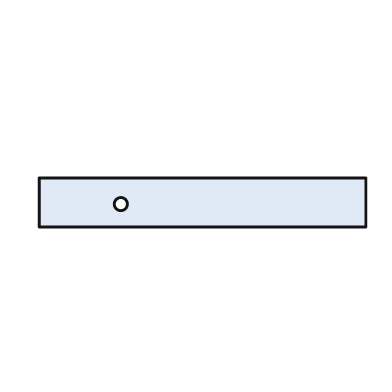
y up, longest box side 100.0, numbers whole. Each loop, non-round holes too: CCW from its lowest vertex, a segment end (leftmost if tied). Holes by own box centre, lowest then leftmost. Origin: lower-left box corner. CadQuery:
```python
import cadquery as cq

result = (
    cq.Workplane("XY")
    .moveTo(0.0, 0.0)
    .lineTo(100.0, 0.0)
    .lineTo(100.0, 15.0)
    .lineTo(0.0, 15.0)
    .close()
    .moveTo(25.0, 7.0)
    .circle(2.0)
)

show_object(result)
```